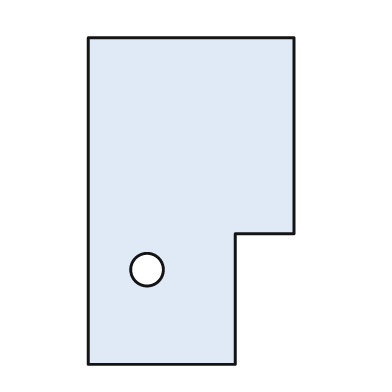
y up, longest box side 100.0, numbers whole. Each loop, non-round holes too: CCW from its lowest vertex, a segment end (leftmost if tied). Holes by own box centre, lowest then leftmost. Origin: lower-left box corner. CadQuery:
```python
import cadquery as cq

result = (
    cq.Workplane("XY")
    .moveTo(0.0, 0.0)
    .lineTo(45.0, 0.0)
    .lineTo(45.0, 40.0)
    .lineTo(63.0, 40.0)
    .lineTo(63.0, 100.0)
    .lineTo(0.0, 100.0)
    .close()
    .moveTo(18.0, 29.0)
    .circle(5.0)
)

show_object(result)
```